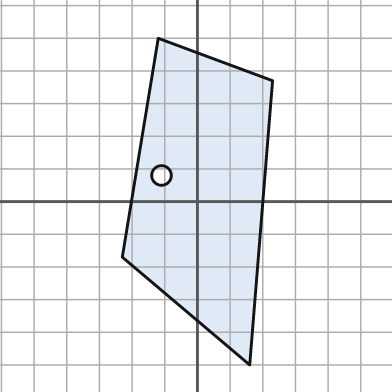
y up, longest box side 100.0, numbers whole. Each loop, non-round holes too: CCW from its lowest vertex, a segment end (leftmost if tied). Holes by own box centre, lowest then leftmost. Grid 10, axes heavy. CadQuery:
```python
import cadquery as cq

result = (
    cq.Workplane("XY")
    .moveTo(16.0, -50.0)
    .lineTo(23.0, 37.0)
    .lineTo(-12.0, 50.0)
    .lineTo(-23.0, -17.0)
    .close()
    .moveTo(-11.0, 8.0)
    .circle(3.0)
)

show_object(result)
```